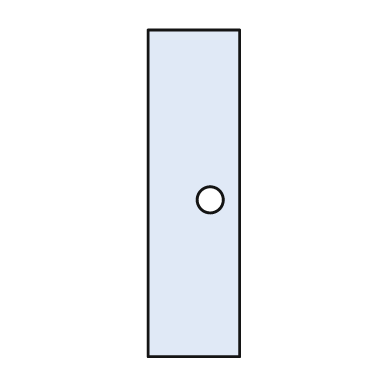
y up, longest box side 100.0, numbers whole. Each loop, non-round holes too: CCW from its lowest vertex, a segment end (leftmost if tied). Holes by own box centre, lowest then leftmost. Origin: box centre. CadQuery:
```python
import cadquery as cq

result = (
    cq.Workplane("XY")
    .moveTo(-14.0, -50.0)
    .lineTo(14.0, -50.0)
    .lineTo(14.0, 50.0)
    .lineTo(-14.0, 50.0)
    .close()
    .moveTo(5.0, -2.0)
    .circle(4.0)
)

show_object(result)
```